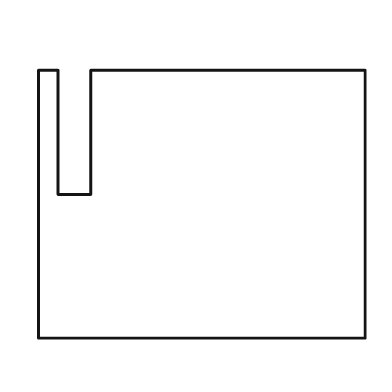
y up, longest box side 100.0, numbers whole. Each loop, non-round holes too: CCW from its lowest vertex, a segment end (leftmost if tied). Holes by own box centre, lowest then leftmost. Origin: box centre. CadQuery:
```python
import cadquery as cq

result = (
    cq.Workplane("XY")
    .moveTo(-50.0, -41.0)
    .lineTo(50.0, -41.0)
    .lineTo(50.0, 41.0)
    .lineTo(-34.0, 41.0)
    .lineTo(-34.0, 3.0)
    .lineTo(-44.0, 3.0)
    .lineTo(-44.0, 41.0)
    .lineTo(-50.0, 41.0)
    .close()
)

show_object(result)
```